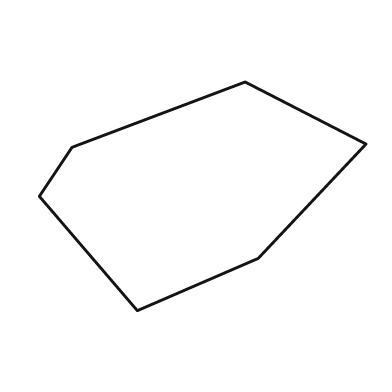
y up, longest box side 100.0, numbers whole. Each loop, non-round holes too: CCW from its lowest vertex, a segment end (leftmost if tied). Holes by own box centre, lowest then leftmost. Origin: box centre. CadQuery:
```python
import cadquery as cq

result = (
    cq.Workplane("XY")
    .moveTo(-20.0, -35.0)
    .lineTo(17.0, -19.0)
    .lineTo(50.0, 16.0)
    .lineTo(13.0, 35.0)
    .lineTo(-40.0, 15.0)
    .lineTo(-50.0, 0.0)
    .close()
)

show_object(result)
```